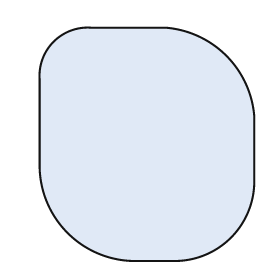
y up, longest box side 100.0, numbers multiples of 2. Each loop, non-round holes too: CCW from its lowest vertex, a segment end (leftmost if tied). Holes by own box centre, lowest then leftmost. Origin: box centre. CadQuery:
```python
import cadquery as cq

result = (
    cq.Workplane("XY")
    .moveTo(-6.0, -50.0)
    .lineTo(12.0, -50.0)
    .threePointArc((36.0, -40.0), (46.0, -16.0))
    .lineTo(46.0, 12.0)
    .threePointArc((34.0, 38.0), (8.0, 50.0))
    .lineTo(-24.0, 50.0)
    .threePointArc((-40.0, 44.0), (-46.0, 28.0))
    .lineTo(-46.0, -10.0)
    .threePointArc((-34.0, -38.0), (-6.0, -50.0))
    .close()
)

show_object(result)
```